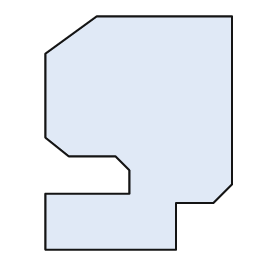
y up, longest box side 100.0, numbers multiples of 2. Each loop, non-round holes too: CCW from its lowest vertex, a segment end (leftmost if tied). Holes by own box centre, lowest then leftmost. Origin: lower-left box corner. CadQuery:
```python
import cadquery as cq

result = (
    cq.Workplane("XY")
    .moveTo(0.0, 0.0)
    .lineTo(56.0, 0.0)
    .lineTo(56.0, 20.0)
    .lineTo(72.0, 20.0)
    .lineTo(80.0, 28.0)
    .lineTo(80.0, 100.0)
    .lineTo(22.0, 100.0)
    .lineTo(0.0, 84.0)
    .lineTo(0.0, 48.0)
    .lineTo(10.0, 40.0)
    .lineTo(30.0, 40.0)
    .lineTo(36.0, 34.0)
    .lineTo(36.0, 24.0)
    .lineTo(0.0, 24.0)
    .close()
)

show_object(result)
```